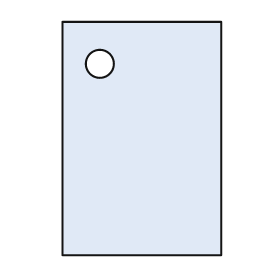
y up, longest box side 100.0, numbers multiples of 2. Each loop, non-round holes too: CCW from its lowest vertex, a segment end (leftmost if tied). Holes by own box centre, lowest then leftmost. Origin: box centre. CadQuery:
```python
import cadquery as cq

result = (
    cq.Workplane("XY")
    .moveTo(-34.0, -50.0)
    .lineTo(34.0, -50.0)
    .lineTo(34.0, 50.0)
    .lineTo(-34.0, 50.0)
    .close()
    .moveTo(-18.0, 32.0)
    .circle(6.0)
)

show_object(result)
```